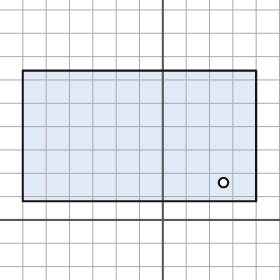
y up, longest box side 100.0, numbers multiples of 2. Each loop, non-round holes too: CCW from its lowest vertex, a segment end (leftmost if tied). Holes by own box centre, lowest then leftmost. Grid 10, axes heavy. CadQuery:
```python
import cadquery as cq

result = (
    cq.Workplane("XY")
    .moveTo(-60.0, 8.0)
    .lineTo(40.0, 8.0)
    .lineTo(40.0, 64.0)
    .lineTo(-60.0, 64.0)
    .close()
    .moveTo(26.0, 16.0)
    .circle(2.0)
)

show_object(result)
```